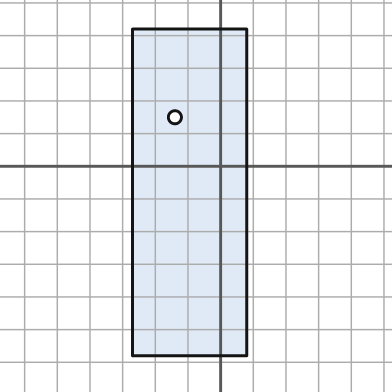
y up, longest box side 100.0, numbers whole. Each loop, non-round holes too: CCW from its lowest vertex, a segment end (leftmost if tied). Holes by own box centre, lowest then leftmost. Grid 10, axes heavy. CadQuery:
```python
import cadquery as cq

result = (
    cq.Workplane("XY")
    .moveTo(-27.0, -58.0)
    .lineTo(8.0, -58.0)
    .lineTo(8.0, 42.0)
    .lineTo(-27.0, 42.0)
    .close()
    .moveTo(-14.0, 15.0)
    .circle(2.0)
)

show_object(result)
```